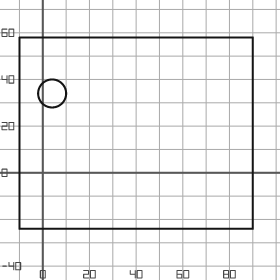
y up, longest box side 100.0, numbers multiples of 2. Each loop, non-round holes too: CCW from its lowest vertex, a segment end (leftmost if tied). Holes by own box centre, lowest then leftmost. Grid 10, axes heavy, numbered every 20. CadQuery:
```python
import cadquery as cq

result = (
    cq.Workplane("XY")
    .moveTo(-10.0, -24.0)
    .lineTo(90.0, -24.0)
    .lineTo(90.0, 58.0)
    .lineTo(-10.0, 58.0)
    .close()
    .moveTo(4.0, 34.0)
    .circle(6.0)
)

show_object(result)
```